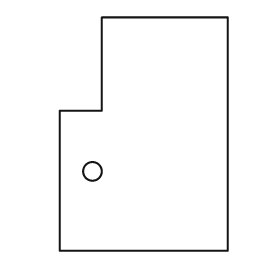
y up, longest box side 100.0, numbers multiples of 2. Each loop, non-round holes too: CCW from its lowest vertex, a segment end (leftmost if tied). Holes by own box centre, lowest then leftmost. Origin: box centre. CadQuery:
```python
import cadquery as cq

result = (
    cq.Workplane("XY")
    .moveTo(-36.0, -50.0)
    .lineTo(36.0, -50.0)
    .lineTo(36.0, 50.0)
    .lineTo(-18.0, 50.0)
    .lineTo(-18.0, 10.0)
    .lineTo(-36.0, 10.0)
    .close()
    .moveTo(-22.0, -16.0)
    .circle(4.0)
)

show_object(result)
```